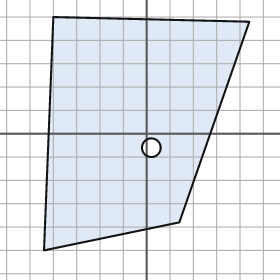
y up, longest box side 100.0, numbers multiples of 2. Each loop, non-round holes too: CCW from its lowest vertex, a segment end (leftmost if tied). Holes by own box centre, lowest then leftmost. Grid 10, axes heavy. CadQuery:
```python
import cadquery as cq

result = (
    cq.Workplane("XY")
    .moveTo(-44.0, -50.0)
    .lineTo(14.0, -38.0)
    .lineTo(44.0, 48.0)
    .lineTo(-40.0, 50.0)
    .close()
    .moveTo(2.0, -6.0)
    .circle(4.0)
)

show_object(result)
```